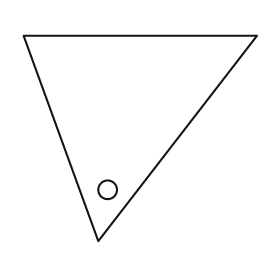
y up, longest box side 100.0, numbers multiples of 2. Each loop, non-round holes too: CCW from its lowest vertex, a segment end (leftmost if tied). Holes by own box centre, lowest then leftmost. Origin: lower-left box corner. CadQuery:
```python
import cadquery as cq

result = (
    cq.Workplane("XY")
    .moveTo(32.0, 0.0)
    .lineTo(100.0, 88.0)
    .lineTo(0.0, 88.0)
    .close()
    .moveTo(36.0, 22.0)
    .circle(4.0)
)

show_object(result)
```